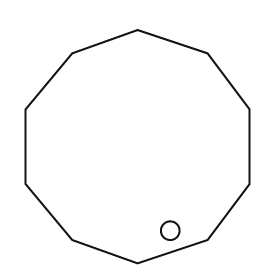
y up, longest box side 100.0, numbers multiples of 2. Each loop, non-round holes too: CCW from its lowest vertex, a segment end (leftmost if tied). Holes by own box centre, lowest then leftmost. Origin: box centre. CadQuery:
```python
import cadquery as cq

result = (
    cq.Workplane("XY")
    .moveTo(0.0, -50.0)
    .lineTo(30.0, -40.0)
    .lineTo(48.0, -16.0)
    .lineTo(48.0, 16.0)
    .lineTo(30.0, 40.0)
    .lineTo(0.0, 50.0)
    .lineTo(-28.0, 40.0)
    .lineTo(-48.0, 16.0)
    .lineTo(-48.0, -16.0)
    .lineTo(-28.0, -40.0)
    .close()
    .moveTo(14.0, -36.0)
    .circle(4.0)
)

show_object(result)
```